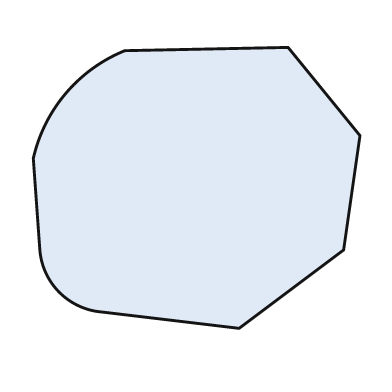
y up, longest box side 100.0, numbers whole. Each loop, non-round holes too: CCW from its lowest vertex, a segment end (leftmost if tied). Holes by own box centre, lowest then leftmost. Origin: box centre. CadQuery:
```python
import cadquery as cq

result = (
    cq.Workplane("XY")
    .moveTo(13.0, -43.0)
    .lineTo(45.0, -19.0)
    .lineTo(50.0, 16.0)
    .lineTo(28.0, 43.0)
    .lineTo(-22.0, 42.0)
    .threePointArc((-40.0, 29.0), (-50.0, 9.0))
    .lineTo(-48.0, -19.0)
    .threePointArc((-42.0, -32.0), (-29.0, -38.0))
    .close()
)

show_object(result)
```